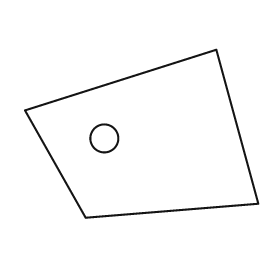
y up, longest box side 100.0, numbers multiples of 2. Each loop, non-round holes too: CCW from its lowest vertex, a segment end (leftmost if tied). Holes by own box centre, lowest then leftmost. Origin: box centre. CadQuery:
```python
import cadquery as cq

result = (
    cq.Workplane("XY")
    .moveTo(-24.0, -36.0)
    .lineTo(50.0, -30.0)
    .lineTo(32.0, 36.0)
    .lineTo(-50.0, 10.0)
    .close()
    .moveTo(-16.0, -2.0)
    .circle(6.0)
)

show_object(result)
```